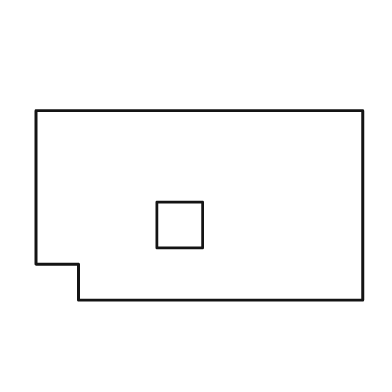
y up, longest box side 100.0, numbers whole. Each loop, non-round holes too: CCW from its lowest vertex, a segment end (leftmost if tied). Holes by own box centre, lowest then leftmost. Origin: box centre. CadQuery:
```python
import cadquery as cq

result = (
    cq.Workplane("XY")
    .moveTo(-37.0, -29.0)
    .lineTo(50.0, -29.0)
    .lineTo(50.0, 29.0)
    .lineTo(-50.0, 29.0)
    .lineTo(-50.0, -18.0)
    .lineTo(-37.0, -18.0)
    .close()
    .moveTo(-13.0, -13.0)
    .lineTo(1.0, -13.0)
    .lineTo(1.0, 1.0)
    .lineTo(-13.0, 1.0)
    .close()
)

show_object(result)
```